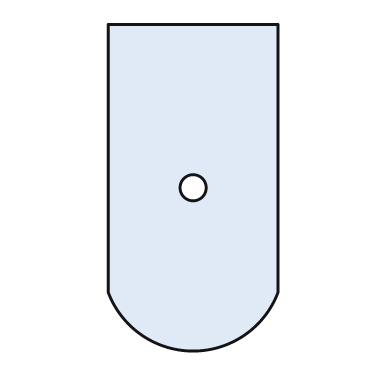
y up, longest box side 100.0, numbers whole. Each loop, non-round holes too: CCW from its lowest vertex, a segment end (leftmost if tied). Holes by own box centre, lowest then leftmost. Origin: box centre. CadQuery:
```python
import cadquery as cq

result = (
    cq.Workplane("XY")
    .moveTo(-26.0, -32.0)
    .threePointArc((0.0, -50.0), (26.0, -32.0))
    .lineTo(26.0, 50.0)
    .lineTo(-26.0, 50.0)
    .close()
    .moveTo(0.0, 0.0)
    .circle(4.0)
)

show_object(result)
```